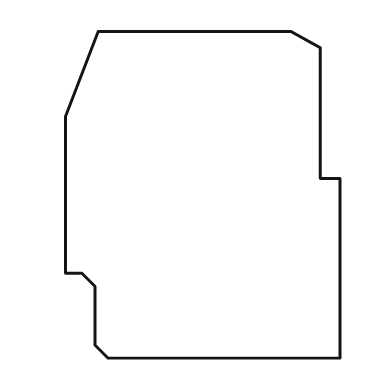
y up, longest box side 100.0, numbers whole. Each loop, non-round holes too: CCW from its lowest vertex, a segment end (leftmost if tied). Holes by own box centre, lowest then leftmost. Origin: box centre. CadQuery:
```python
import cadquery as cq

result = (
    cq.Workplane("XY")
    .moveTo(-29.0, -50.0)
    .lineTo(42.0, -50.0)
    .lineTo(42.0, 5.0)
    .lineTo(36.0, 5.0)
    .lineTo(36.0, 45.0)
    .lineTo(27.0, 50.0)
    .lineTo(-32.0, 50.0)
    .lineTo(-42.0, 24.0)
    .lineTo(-42.0, -24.0)
    .lineTo(-37.0, -24.0)
    .lineTo(-33.0, -28.0)
    .lineTo(-33.0, -46.0)
    .close()
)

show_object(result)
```